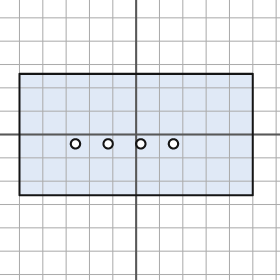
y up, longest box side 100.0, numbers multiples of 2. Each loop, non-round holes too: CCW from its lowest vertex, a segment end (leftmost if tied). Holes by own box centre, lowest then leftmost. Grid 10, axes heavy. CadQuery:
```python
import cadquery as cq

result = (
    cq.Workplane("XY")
    .moveTo(-50.0, -26.0)
    .lineTo(50.0, -26.0)
    .lineTo(50.0, 26.0)
    .lineTo(-50.0, 26.0)
    .close()
    .moveTo(-26.0, -4.0)
    .circle(2.0)
    .moveTo(-12.0, -4.0)
    .circle(2.0)
    .moveTo(2.0, -4.0)
    .circle(2.0)
    .moveTo(16.0, -4.0)
    .circle(2.0)
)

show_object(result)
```